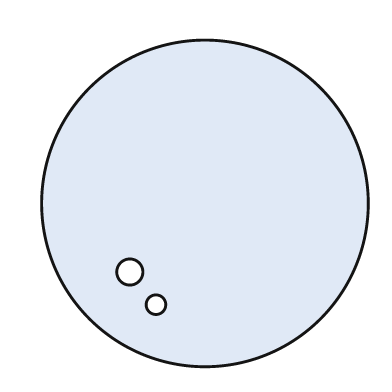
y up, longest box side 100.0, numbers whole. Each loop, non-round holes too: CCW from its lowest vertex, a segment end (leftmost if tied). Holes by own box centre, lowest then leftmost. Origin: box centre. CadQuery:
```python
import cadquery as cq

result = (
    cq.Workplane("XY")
    .moveTo(0.0, 0.0)
    .circle(50.0)
    .moveTo(-15.0, -31.0)
    .circle(3.0)
    .moveTo(-23.0, -21.0)
    .circle(4.0)
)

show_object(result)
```